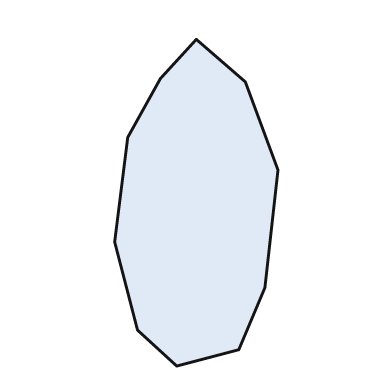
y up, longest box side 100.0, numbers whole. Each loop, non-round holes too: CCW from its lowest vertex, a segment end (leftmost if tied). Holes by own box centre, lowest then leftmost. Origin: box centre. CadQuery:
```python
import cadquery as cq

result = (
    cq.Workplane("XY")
    .moveTo(-6.0, -50.0)
    .lineTo(13.0, -45.0)
    .lineTo(21.0, -26.0)
    .lineTo(25.0, 10.0)
    .lineTo(15.0, 37.0)
    .lineTo(0.0, 50.0)
    .lineTo(-11.0, 38.0)
    .lineTo(-21.0, 20.0)
    .lineTo(-25.0, -12.0)
    .lineTo(-18.0, -39.0)
    .close()
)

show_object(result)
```